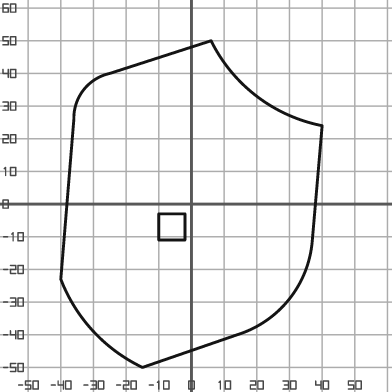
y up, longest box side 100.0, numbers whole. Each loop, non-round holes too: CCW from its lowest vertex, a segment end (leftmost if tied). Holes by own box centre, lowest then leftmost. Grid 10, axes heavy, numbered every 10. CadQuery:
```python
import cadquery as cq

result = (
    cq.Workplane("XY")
    .moveTo(-15.0, -50.0)
    .lineTo(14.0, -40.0)
    .threePointArc((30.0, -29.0), (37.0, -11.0))
    .lineTo(40.0, 24.0)
    .threePointArc((20.0, 33.0), (6.0, 50.0))
    .lineTo(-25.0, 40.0)
    .threePointArc((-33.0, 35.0), (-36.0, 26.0))
    .lineTo(-40.0, -23.0)
    .threePointArc((-30.0, -39.0), (-15.0, -50.0))
    .close()
    .moveTo(-10.0, -11.0)
    .lineTo(-2.0, -11.0)
    .lineTo(-2.0, -3.0)
    .lineTo(-10.0, -3.0)
    .close()
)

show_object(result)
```